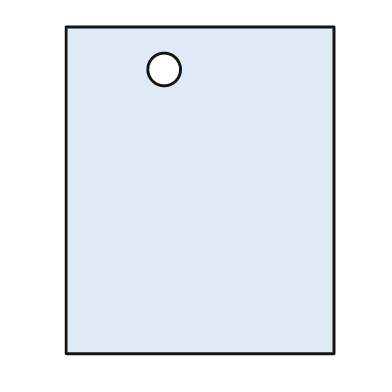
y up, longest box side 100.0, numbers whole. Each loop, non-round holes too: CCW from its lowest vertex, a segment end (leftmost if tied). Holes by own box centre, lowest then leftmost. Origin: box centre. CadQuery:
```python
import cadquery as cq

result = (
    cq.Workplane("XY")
    .moveTo(-41.0, -50.0)
    .lineTo(41.0, -50.0)
    .lineTo(41.0, 50.0)
    .lineTo(-41.0, 50.0)
    .close()
    .moveTo(-11.0, 37.0)
    .circle(5.0)
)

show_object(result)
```